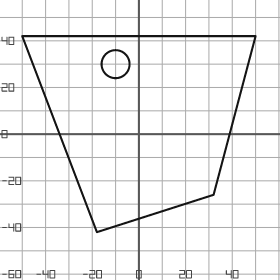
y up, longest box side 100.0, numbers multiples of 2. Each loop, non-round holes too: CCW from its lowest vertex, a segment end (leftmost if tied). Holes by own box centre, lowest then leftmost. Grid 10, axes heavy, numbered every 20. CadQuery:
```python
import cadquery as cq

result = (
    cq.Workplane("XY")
    .moveTo(-18.0, -42.0)
    .lineTo(32.0, -26.0)
    .lineTo(50.0, 42.0)
    .lineTo(-50.0, 42.0)
    .close()
    .moveTo(-10.0, 30.0)
    .circle(6.0)
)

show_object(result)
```